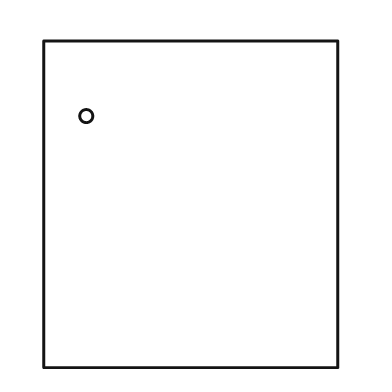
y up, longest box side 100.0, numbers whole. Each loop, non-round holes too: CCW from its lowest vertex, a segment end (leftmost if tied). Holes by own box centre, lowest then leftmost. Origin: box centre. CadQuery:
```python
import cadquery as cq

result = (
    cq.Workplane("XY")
    .moveTo(-45.0, -50.0)
    .lineTo(45.0, -50.0)
    .lineTo(45.0, 50.0)
    .lineTo(-45.0, 50.0)
    .close()
    .moveTo(-32.0, 27.0)
    .circle(2.0)
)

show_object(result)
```